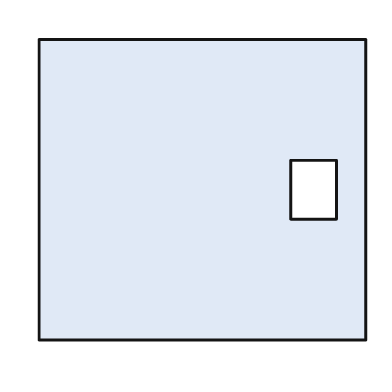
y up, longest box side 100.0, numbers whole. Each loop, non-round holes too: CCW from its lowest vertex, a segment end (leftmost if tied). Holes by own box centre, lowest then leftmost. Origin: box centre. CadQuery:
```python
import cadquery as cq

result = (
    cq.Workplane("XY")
    .moveTo(-50.0, -46.0)
    .lineTo(50.0, -46.0)
    .lineTo(50.0, 46.0)
    .lineTo(-50.0, 46.0)
    .close()
    .moveTo(27.0, -9.0)
    .lineTo(41.0, -9.0)
    .lineTo(41.0, 9.0)
    .lineTo(27.0, 9.0)
    .close()
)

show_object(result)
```